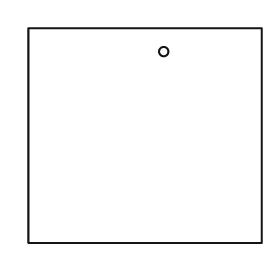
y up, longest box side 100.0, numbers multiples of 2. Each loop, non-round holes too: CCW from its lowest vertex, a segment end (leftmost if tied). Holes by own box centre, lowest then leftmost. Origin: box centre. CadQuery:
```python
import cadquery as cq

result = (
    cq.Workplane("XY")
    .moveTo(-50.0, -46.0)
    .lineTo(50.0, -46.0)
    .lineTo(50.0, 46.0)
    .lineTo(-50.0, 46.0)
    .close()
    .moveTo(8.0, 36.0)
    .circle(2.0)
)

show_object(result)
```